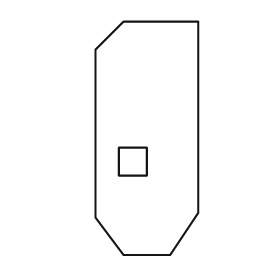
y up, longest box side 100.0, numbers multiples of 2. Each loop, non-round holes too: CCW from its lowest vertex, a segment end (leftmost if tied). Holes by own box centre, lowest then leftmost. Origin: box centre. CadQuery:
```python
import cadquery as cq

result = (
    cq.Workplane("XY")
    .moveTo(-10.0, -50.0)
    .lineTo(10.0, -50.0)
    .lineTo(22.0, -32.0)
    .lineTo(22.0, 50.0)
    .lineTo(-10.0, 50.0)
    .lineTo(-22.0, 38.0)
    .lineTo(-22.0, -34.0)
    .close()
    .moveTo(-12.0, -16.0)
    .lineTo(0.0, -16.0)
    .lineTo(0.0, -4.0)
    .lineTo(-12.0, -4.0)
    .close()
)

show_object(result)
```